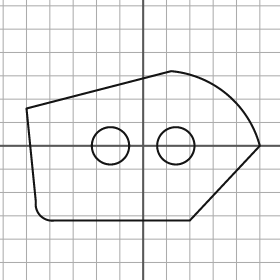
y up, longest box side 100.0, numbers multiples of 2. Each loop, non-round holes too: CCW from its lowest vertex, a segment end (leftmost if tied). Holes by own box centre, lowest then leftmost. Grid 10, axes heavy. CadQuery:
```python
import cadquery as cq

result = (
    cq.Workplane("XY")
    .moveTo(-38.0, -32.0)
    .lineTo(20.0, -32.0)
    .lineTo(50.0, 0.0)
    .threePointArc((36.0, 22.0), (12.0, 32.0))
    .lineTo(-50.0, 16.0)
    .lineTo(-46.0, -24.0)
    .threePointArc((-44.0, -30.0), (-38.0, -32.0))
    .close()
    .moveTo(-14.0, 0.0)
    .circle(8.0)
    .moveTo(14.0, 0.0)
    .circle(8.0)
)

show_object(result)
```